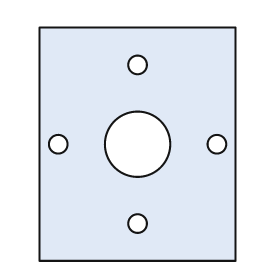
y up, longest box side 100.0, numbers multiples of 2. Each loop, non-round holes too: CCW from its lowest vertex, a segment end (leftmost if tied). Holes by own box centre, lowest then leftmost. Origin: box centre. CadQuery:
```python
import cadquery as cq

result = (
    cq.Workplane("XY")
    .moveTo(-42.0, -50.0)
    .lineTo(42.0, -50.0)
    .lineTo(42.0, 50.0)
    .lineTo(-42.0, 50.0)
    .close()
    .moveTo(0.0, -34.0)
    .circle(4.0)
    .moveTo(-34.0, 0.0)
    .circle(4.0)
    .moveTo(0.0, 0.0)
    .circle(14.0)
    .moveTo(34.0, 0.0)
    .circle(4.0)
    .moveTo(0.0, 34.0)
    .circle(4.0)
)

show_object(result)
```